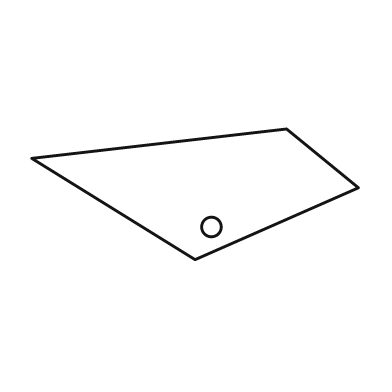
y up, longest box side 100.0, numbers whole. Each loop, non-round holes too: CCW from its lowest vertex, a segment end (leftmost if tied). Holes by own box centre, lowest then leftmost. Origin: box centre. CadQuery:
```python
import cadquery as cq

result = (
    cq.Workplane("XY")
    .moveTo(0.0, -20.0)
    .lineTo(50.0, 2.0)
    .lineTo(28.0, 20.0)
    .lineTo(-50.0, 11.0)
    .close()
    .moveTo(5.0, -10.0)
    .circle(3.0)
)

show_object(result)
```